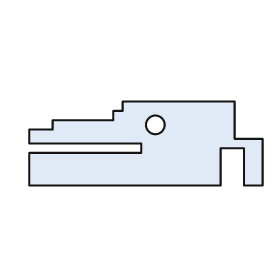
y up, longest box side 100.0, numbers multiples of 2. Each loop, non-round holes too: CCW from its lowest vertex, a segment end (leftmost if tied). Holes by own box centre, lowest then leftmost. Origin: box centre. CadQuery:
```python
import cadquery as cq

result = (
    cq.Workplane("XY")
    .moveTo(-50.0, -18.0)
    .lineTo(32.0, -18.0)
    .lineTo(32.0, -2.0)
    .lineTo(42.0, -2.0)
    .lineTo(42.0, -18.0)
    .lineTo(50.0, -18.0)
    .lineTo(50.0, 2.0)
    .lineTo(38.0, 2.0)
    .lineTo(38.0, 18.0)
    .lineTo(-10.0, 18.0)
    .lineTo(-10.0, 14.0)
    .lineTo(-14.0, 14.0)
    .lineTo(-14.0, 10.0)
    .lineTo(-40.0, 10.0)
    .lineTo(-40.0, 6.0)
    .lineTo(-50.0, 6.0)
    .lineTo(-50.0, 0.0)
    .lineTo(-2.0, 0.0)
    .lineTo(-2.0, -4.0)
    .lineTo(-50.0, -4.0)
    .close()
    .moveTo(4.0, 8.0)
    .circle(4.0)
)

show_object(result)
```